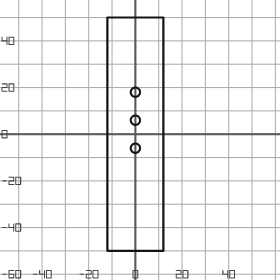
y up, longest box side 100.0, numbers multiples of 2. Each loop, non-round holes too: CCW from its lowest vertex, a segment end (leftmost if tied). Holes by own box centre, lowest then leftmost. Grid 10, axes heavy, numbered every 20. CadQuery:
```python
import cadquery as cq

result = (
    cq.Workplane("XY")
    .moveTo(-12.0, -50.0)
    .lineTo(12.0, -50.0)
    .lineTo(12.0, 50.0)
    .lineTo(-12.0, 50.0)
    .close()
    .moveTo(0.0, -6.0)
    .circle(2.0)
    .moveTo(0.0, 6.0)
    .circle(2.0)
    .moveTo(0.0, 18.0)
    .circle(2.0)
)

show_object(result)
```